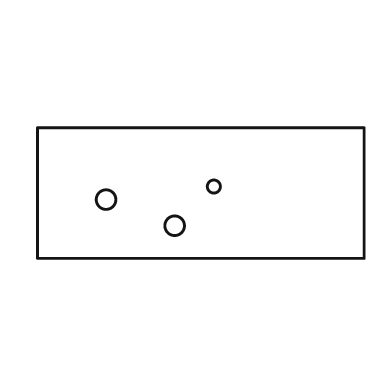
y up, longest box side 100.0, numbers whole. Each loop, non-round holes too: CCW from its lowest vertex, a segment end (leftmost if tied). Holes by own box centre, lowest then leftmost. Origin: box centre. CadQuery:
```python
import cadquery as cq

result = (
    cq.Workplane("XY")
    .moveTo(-50.0, -20.0)
    .lineTo(50.0, -20.0)
    .lineTo(50.0, 20.0)
    .lineTo(-50.0, 20.0)
    .close()
    .moveTo(-8.0, -10.0)
    .circle(3.0)
    .moveTo(-29.0, -2.0)
    .circle(3.0)
    .moveTo(4.0, 2.0)
    .circle(2.0)
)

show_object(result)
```